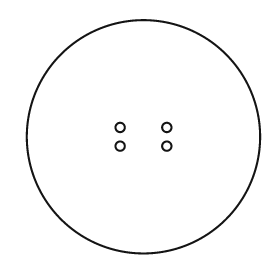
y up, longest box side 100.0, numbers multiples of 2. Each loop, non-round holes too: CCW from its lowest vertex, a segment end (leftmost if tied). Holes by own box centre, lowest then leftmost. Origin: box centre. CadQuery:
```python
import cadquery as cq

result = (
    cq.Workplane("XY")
    .moveTo(0.0, 0.0)
    .circle(50.0)
    .moveTo(-10.0, -4.0)
    .circle(2.0)
    .moveTo(10.0, -4.0)
    .circle(2.0)
    .moveTo(-10.0, 4.0)
    .circle(2.0)
    .moveTo(10.0, 4.0)
    .circle(2.0)
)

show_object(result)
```